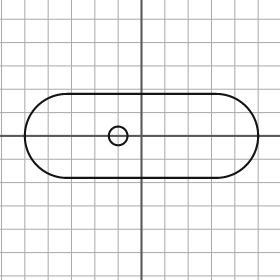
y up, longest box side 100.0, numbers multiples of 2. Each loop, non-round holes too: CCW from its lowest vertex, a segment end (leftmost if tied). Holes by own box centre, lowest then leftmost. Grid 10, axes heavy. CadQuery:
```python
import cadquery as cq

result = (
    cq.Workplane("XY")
    .moveTo(-32.0, -18.0)
    .lineTo(32.0, -18.0)
    .threePointArc((50.0, 0.0), (32.0, 18.0))
    .lineTo(-32.0, 18.0)
    .threePointArc((-50.0, 0.0), (-32.0, -18.0))
    .close()
    .moveTo(-10.0, 0.0)
    .circle(4.0)
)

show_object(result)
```